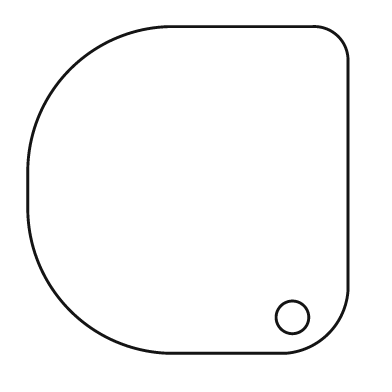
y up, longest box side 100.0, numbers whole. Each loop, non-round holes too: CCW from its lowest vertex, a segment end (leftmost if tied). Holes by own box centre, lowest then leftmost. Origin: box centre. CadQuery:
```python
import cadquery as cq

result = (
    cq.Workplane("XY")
    .moveTo(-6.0, -50.0)
    .lineTo(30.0, -50.0)
    .threePointArc((43.0, -44.0), (49.0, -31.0))
    .lineTo(49.0, 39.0)
    .threePointArc((46.0, 47.0), (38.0, 50.0))
    .lineTo(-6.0, 50.0)
    .threePointArc((-36.0, 37.0), (-49.0, 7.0))
    .lineTo(-49.0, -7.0)
    .threePointArc((-36.0, -37.0), (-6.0, -50.0))
    .close()
    .moveTo(32.0, -39.0)
    .circle(5.0)
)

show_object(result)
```